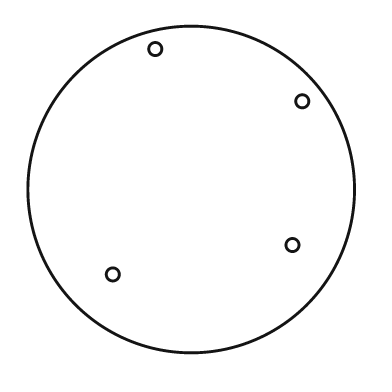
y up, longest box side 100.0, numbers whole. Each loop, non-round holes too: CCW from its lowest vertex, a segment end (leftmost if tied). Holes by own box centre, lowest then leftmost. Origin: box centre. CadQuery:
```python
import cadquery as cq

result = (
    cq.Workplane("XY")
    .moveTo(0.0, 0.0)
    .circle(50.0)
    .moveTo(-24.0, -26.0)
    .circle(2.0)
    .moveTo(31.0, -17.0)
    .circle(2.0)
    .moveTo(34.0, 27.0)
    .circle(2.0)
    .moveTo(-11.0, 43.0)
    .circle(2.0)
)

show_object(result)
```